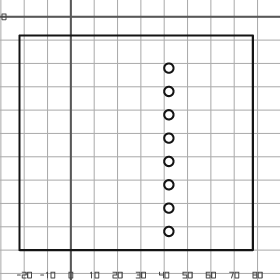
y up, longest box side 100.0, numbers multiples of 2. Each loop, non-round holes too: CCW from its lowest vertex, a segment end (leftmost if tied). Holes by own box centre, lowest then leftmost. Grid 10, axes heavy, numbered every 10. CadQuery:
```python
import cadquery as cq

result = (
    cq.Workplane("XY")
    .moveTo(-22.0, -100.0)
    .lineTo(78.0, -100.0)
    .lineTo(78.0, -8.0)
    .lineTo(-22.0, -8.0)
    .close()
    .moveTo(42.0, -92.0)
    .circle(2.0)
    .moveTo(42.0, -82.0)
    .circle(2.0)
    .moveTo(42.0, -72.0)
    .circle(2.0)
    .moveTo(42.0, -62.0)
    .circle(2.0)
    .moveTo(42.0, -52.0)
    .circle(2.0)
    .moveTo(42.0, -42.0)
    .circle(2.0)
    .moveTo(42.0, -32.0)
    .circle(2.0)
    .moveTo(42.0, -22.0)
    .circle(2.0)
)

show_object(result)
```